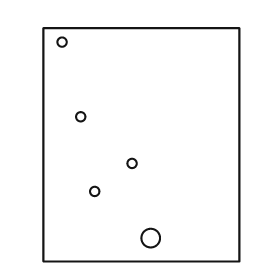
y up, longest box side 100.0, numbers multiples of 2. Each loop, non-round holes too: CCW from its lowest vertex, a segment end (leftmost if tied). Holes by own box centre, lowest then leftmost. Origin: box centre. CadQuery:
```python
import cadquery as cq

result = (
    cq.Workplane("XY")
    .moveTo(-42.0, -50.0)
    .lineTo(42.0, -50.0)
    .lineTo(42.0, 50.0)
    .lineTo(-42.0, 50.0)
    .close()
    .moveTo(4.0, -40.0)
    .circle(4.0)
    .moveTo(-20.0, -20.0)
    .circle(2.0)
    .moveTo(-4.0, -8.0)
    .circle(2.0)
    .moveTo(-26.0, 12.0)
    .circle(2.0)
    .moveTo(-34.0, 44.0)
    .circle(2.0)
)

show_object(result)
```